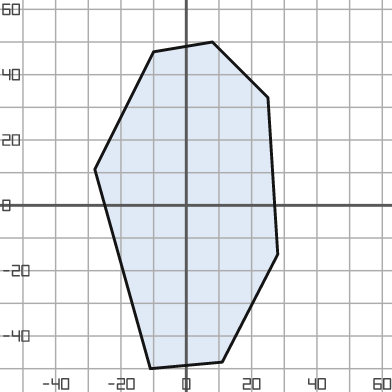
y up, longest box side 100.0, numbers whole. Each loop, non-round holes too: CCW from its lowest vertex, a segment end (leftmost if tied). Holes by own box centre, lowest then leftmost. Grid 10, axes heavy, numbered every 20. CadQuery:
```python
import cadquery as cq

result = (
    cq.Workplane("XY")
    .moveTo(-11.0, -50.0)
    .lineTo(11.0, -48.0)
    .lineTo(28.0, -15.0)
    .lineTo(25.0, 33.0)
    .lineTo(8.0, 50.0)
    .lineTo(-10.0, 47.0)
    .lineTo(-28.0, 11.0)
    .close()
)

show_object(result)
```